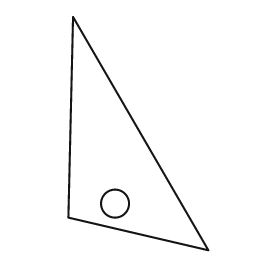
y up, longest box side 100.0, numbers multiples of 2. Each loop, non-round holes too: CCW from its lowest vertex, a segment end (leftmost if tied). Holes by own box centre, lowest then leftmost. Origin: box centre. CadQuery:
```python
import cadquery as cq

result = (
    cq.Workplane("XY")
    .moveTo(30.0, -50.0)
    .lineTo(-28.0, 50.0)
    .lineTo(-30.0, -36.0)
    .close()
    .moveTo(-10.0, -30.0)
    .circle(6.0)
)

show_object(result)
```